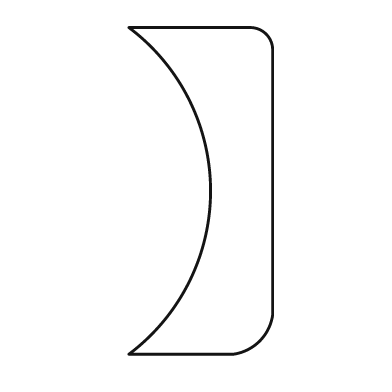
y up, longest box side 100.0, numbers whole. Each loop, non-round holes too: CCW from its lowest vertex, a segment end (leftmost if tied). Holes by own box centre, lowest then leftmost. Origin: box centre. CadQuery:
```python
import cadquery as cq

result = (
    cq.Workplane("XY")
    .moveTo(-22.0, -50.0)
    .lineTo(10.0, -50.0)
    .threePointArc((18.0, -46.0), (22.0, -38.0))
    .lineTo(22.0, 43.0)
    .threePointArc((20.0, 48.0), (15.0, 50.0))
    .lineTo(-22.0, 50.0)
    .threePointArc((3.0, 0.0), (-22.0, -50.0))
    .close()
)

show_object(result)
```